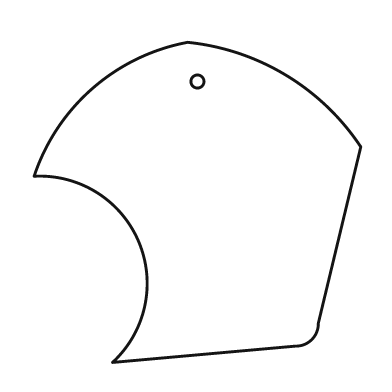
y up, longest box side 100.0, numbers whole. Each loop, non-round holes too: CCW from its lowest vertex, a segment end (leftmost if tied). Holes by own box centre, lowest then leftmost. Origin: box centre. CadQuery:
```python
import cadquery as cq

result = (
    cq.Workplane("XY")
    .moveTo(-26.0, -49.0)
    .lineTo(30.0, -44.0)
    .threePointArc((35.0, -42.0), (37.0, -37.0))
    .lineTo(50.0, 17.0)
    .threePointArc((27.0, 39.0), (-3.0, 49.0))
    .threePointArc((-32.0, 35.0), (-50.0, 8.0))
    .threePointArc((-18.0, -12.0), (-26.0, -49.0))
    .close()
    .moveTo(0.0, 37.0)
    .circle(2.0)
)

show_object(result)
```